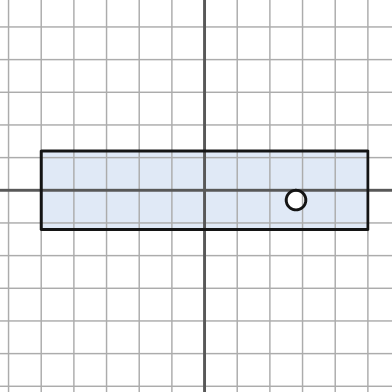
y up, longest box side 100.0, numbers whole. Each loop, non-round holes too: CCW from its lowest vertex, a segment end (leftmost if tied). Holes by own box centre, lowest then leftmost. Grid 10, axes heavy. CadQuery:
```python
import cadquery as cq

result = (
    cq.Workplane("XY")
    .moveTo(-50.0, -12.0)
    .lineTo(50.0, -12.0)
    .lineTo(50.0, 12.0)
    .lineTo(-50.0, 12.0)
    .close()
    .moveTo(28.0, -3.0)
    .circle(3.0)
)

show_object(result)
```